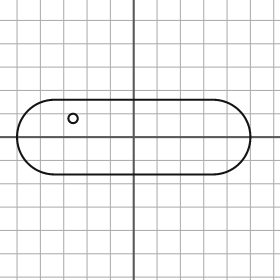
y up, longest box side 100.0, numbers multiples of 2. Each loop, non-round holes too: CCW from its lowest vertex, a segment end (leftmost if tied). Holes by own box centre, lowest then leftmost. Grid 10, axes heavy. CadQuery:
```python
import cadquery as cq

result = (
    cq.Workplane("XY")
    .moveTo(-34.0, -16.0)
    .lineTo(34.0, -16.0)
    .threePointArc((50.0, 0.0), (34.0, 16.0))
    .lineTo(-34.0, 16.0)
    .threePointArc((-50.0, 0.0), (-34.0, -16.0))
    .close()
    .moveTo(-26.0, 8.0)
    .circle(2.0)
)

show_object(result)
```